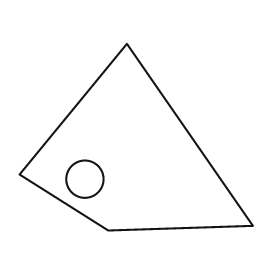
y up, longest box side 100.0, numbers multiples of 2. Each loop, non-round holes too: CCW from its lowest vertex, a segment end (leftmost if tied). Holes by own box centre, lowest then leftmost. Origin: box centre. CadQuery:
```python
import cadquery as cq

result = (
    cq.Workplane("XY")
    .moveTo(-12.0, -40.0)
    .lineTo(50.0, -38.0)
    .lineTo(-4.0, 40.0)
    .lineTo(-50.0, -16.0)
    .close()
    .moveTo(-22.0, -18.0)
    .circle(8.0)
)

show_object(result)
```